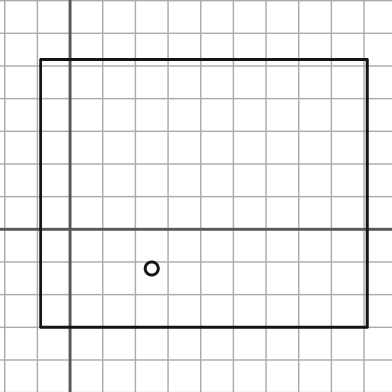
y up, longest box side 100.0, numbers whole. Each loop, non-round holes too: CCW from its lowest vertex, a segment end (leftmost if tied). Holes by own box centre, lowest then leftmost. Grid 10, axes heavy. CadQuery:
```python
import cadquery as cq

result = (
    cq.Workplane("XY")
    .moveTo(-9.0, -30.0)
    .lineTo(91.0, -30.0)
    .lineTo(91.0, 52.0)
    .lineTo(-9.0, 52.0)
    .close()
    .moveTo(25.0, -12.0)
    .circle(2.0)
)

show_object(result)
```